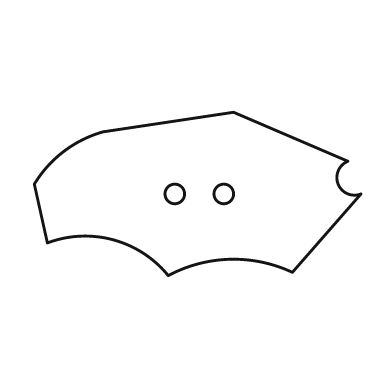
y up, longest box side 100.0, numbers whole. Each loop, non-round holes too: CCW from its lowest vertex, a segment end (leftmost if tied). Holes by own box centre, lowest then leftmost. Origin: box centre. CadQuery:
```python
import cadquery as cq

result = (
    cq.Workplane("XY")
    .moveTo(-9.0, -25.0)
    .threePointArc((10.0, -20.0), (29.0, -24.0))
    .lineTo(50.0, 0.0)
    .threePointArc((43.0, 3.0), (46.0, 10.0))
    .lineTo(11.0, 25.0)
    .lineTo(-29.0, 19.0)
    .threePointArc((-41.0, 13.0), (-50.0, 3.0))
    .lineTo(-46.0, -15.0)
    .threePointArc((-26.0, -14.0), (-9.0, -25.0))
    .close()
    .moveTo(-7.0, 0.0)
    .circle(3.0)
    .moveTo(8.0, 0.0)
    .circle(3.0)
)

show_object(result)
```